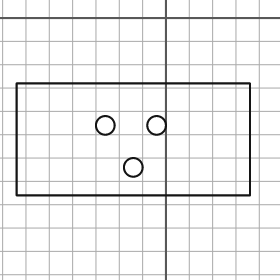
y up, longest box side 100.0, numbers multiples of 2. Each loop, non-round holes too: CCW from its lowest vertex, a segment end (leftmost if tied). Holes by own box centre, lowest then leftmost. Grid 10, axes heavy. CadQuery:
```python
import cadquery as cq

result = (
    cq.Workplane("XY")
    .moveTo(-64.0, -76.0)
    .lineTo(36.0, -76.0)
    .lineTo(36.0, -28.0)
    .lineTo(-64.0, -28.0)
    .close()
    .moveTo(-14.0, -64.0)
    .circle(4.0)
    .moveTo(-26.0, -46.0)
    .circle(4.0)
    .moveTo(-4.0, -46.0)
    .circle(4.0)
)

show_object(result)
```